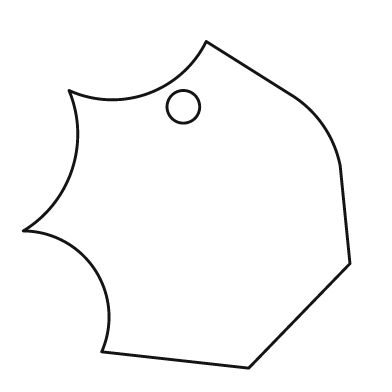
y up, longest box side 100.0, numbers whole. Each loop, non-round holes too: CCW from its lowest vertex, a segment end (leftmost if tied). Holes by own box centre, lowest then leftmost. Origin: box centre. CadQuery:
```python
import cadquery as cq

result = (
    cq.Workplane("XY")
    .moveTo(19.0, -50.0)
    .lineTo(50.0, -18.0)
    .lineTo(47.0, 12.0)
    .threePointArc((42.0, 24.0), (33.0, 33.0))
    .lineTo(6.0, 50.0)
    .threePointArc((-12.0, 34.0), (-36.0, 35.0))
    .threePointArc((-35.0, 11.0), (-50.0, -8.0))
    .threePointArc((-28.0, -20.0), (-26.0, -45.0))
    .close()
    .moveTo(-1.0, 30.0)
    .circle(5.0)
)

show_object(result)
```